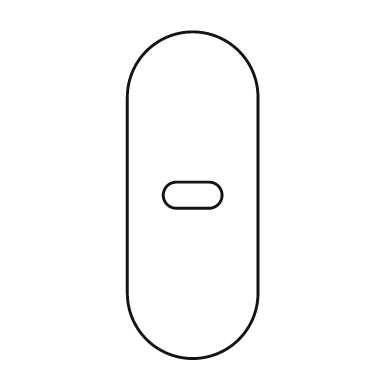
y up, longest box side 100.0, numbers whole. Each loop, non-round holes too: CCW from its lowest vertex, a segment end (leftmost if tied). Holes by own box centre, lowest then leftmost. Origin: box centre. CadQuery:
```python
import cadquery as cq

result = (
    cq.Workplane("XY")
    .moveTo(-20.0, -30.0)
    .threePointArc((0.0, -50.0), (20.0, -30.0))
    .lineTo(20.0, 30.0)
    .threePointArc((0.0, 50.0), (-20.0, 30.0))
    .close()
    .moveTo(-5.0, -4.0)
    .lineTo(5.0, -4.0)
    .threePointArc((9.0, 0.0), (5.0, 4.0))
    .lineTo(-5.0, 4.0)
    .threePointArc((-9.0, 0.0), (-5.0, -4.0))
    .close()
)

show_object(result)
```